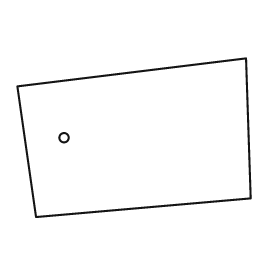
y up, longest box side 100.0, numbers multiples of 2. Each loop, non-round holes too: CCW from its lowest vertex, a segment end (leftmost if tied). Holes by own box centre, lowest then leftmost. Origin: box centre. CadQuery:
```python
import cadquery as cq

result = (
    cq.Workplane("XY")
    .moveTo(-42.0, -34.0)
    .lineTo(50.0, -26.0)
    .lineTo(48.0, 34.0)
    .lineTo(-50.0, 22.0)
    .close()
    .moveTo(-30.0, 0.0)
    .circle(2.0)
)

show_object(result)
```